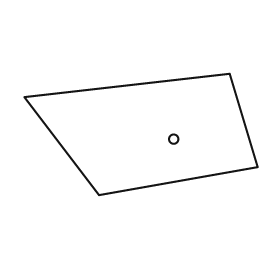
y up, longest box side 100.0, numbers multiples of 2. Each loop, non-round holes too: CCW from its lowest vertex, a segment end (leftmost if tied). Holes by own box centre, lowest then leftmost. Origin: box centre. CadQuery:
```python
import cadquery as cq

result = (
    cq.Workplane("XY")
    .moveTo(-18.0, -26.0)
    .lineTo(50.0, -14.0)
    .lineTo(38.0, 26.0)
    .lineTo(-50.0, 16.0)
    .close()
    .moveTo(14.0, -2.0)
    .circle(2.0)
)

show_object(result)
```